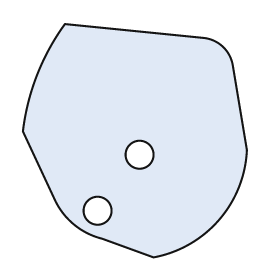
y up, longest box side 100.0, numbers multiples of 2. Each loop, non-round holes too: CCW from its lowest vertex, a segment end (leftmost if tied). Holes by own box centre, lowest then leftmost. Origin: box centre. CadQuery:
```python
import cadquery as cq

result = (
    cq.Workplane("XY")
    .moveTo(8.0, -50.0)
    .threePointArc((36.0, -34.0), (48.0, -4.0))
    .lineTo(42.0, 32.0)
    .threePointArc((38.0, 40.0), (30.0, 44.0))
    .lineTo(-30.0, 50.0)
    .threePointArc((-42.0, 28.0), (-48.0, 4.0))
    .lineTo(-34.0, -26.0)
    .threePointArc((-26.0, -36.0), (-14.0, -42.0))
    .close()
    .moveTo(-16.0, -30.0)
    .circle(6.0)
    .moveTo(2.0, -6.0)
    .circle(6.0)
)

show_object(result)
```